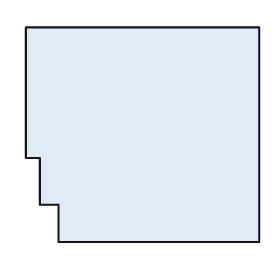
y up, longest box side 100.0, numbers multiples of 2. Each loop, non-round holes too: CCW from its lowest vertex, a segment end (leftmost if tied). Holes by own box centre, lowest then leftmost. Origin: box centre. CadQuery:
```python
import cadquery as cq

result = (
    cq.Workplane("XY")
    .moveTo(-36.0, -46.0)
    .lineTo(50.0, -46.0)
    .lineTo(50.0, 46.0)
    .lineTo(-50.0, 46.0)
    .lineTo(-50.0, -10.0)
    .lineTo(-44.0, -10.0)
    .lineTo(-44.0, -30.0)
    .lineTo(-36.0, -30.0)
    .close()
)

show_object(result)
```